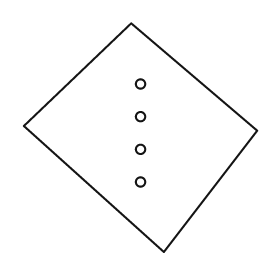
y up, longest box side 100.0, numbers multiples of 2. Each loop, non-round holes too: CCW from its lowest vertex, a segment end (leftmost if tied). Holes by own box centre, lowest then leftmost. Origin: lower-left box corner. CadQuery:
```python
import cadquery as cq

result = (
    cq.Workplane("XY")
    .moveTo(60.0, 0.0)
    .lineTo(100.0, 52.0)
    .lineTo(46.0, 98.0)
    .lineTo(0.0, 54.0)
    .close()
    .moveTo(50.0, 30.0)
    .circle(2.0)
    .moveTo(50.0, 44.0)
    .circle(2.0)
    .moveTo(50.0, 58.0)
    .circle(2.0)
    .moveTo(50.0, 72.0)
    .circle(2.0)
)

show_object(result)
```